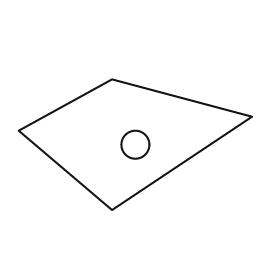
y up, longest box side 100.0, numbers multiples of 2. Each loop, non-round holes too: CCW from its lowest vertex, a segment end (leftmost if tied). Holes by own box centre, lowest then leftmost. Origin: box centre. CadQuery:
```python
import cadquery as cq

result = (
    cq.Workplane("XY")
    .moveTo(-10.0, -28.0)
    .lineTo(50.0, 12.0)
    .lineTo(-10.0, 28.0)
    .lineTo(-50.0, 6.0)
    .close()
    .moveTo(0.0, 0.0)
    .circle(6.0)
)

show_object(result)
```